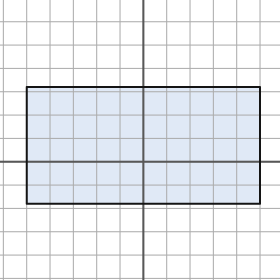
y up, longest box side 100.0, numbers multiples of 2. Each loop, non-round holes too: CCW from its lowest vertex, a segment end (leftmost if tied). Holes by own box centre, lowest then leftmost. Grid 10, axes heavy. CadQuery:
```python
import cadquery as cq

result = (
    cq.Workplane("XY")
    .moveTo(-50.0, -18.0)
    .lineTo(50.0, -18.0)
    .lineTo(50.0, 32.0)
    .lineTo(-50.0, 32.0)
    .close()
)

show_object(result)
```